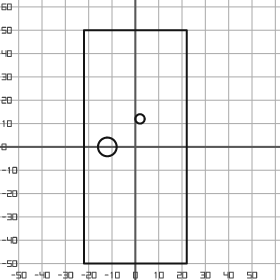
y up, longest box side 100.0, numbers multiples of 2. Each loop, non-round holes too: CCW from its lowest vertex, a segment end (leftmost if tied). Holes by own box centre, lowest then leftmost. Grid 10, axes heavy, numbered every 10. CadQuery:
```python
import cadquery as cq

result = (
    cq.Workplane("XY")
    .moveTo(-22.0, -50.0)
    .lineTo(22.0, -50.0)
    .lineTo(22.0, 50.0)
    .lineTo(-22.0, 50.0)
    .close()
    .moveTo(-12.0, 0.0)
    .circle(4.0)
    .moveTo(2.0, 12.0)
    .circle(2.0)
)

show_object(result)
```